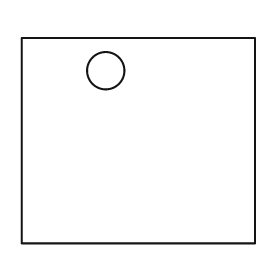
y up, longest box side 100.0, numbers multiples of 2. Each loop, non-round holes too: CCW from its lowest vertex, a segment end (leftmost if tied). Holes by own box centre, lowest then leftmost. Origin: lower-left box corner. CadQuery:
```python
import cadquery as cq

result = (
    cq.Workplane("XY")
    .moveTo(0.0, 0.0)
    .lineTo(100.0, 0.0)
    .lineTo(100.0, 88.0)
    .lineTo(0.0, 88.0)
    .close()
    .moveTo(36.0, 74.0)
    .circle(8.0)
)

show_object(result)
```